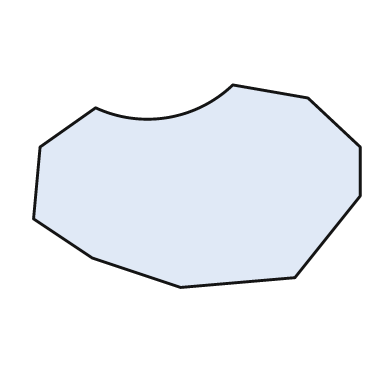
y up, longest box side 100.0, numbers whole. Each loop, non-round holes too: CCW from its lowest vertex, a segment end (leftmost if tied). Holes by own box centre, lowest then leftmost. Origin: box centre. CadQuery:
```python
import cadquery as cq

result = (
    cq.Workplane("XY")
    .moveTo(-5.0, -31.0)
    .lineTo(30.0, -28.0)
    .lineTo(50.0, -3.0)
    .lineTo(50.0, 12.0)
    .lineTo(34.0, 27.0)
    .lineTo(11.0, 31.0)
    .threePointArc((-9.0, 21.0), (-31.0, 24.0))
    .lineTo(-48.0, 12.0)
    .lineTo(-50.0, -10.0)
    .lineTo(-32.0, -22.0)
    .close()
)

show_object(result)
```